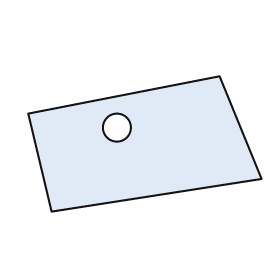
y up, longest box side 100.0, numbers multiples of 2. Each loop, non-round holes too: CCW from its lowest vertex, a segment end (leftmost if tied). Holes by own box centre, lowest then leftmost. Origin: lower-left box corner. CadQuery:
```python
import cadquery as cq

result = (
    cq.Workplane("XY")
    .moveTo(10.0, 0.0)
    .lineTo(100.0, 14.0)
    .lineTo(82.0, 58.0)
    .lineTo(0.0, 42.0)
    .close()
    .moveTo(38.0, 36.0)
    .circle(6.0)
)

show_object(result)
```